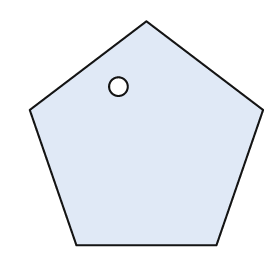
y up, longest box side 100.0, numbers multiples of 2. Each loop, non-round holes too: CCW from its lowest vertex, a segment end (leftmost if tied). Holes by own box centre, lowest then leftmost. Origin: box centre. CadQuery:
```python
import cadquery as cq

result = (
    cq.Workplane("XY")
    .moveTo(-30.0, -48.0)
    .lineTo(30.0, -48.0)
    .lineTo(50.0, 10.0)
    .lineTo(0.0, 48.0)
    .lineTo(-50.0, 10.0)
    .close()
    .moveTo(-12.0, 20.0)
    .circle(4.0)
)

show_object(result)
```